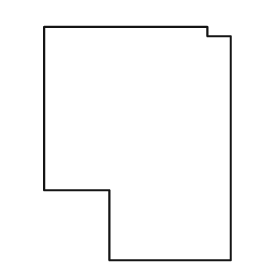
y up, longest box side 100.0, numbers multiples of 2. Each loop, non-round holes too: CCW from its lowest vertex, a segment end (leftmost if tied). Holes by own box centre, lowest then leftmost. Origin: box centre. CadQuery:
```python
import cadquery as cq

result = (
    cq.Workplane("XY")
    .moveTo(-12.0, -50.0)
    .lineTo(40.0, -50.0)
    .lineTo(40.0, 46.0)
    .lineTo(30.0, 46.0)
    .lineTo(30.0, 50.0)
    .lineTo(-40.0, 50.0)
    .lineTo(-40.0, -20.0)
    .lineTo(-12.0, -20.0)
    .close()
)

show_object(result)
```